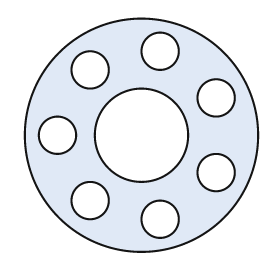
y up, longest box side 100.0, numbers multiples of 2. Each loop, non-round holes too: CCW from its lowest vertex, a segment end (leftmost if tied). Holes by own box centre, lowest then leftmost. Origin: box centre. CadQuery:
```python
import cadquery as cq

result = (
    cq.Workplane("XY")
    .moveTo(0.0, 0.0)
    .circle(50.0)
    .moveTo(8.0, -36.0)
    .circle(8.0)
    .moveTo(-22.0, -28.0)
    .circle(8.0)
    .moveTo(32.0, -16.0)
    .circle(8.0)
    .moveTo(-36.0, 0.0)
    .circle(8.0)
    .moveTo(0.0, 0.0)
    .circle(20.0)
    .moveTo(32.0, 16.0)
    .circle(8.0)
    .moveTo(-22.0, 28.0)
    .circle(8.0)
    .moveTo(8.0, 36.0)
    .circle(8.0)
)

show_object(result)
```